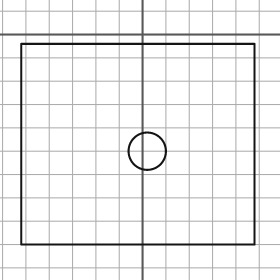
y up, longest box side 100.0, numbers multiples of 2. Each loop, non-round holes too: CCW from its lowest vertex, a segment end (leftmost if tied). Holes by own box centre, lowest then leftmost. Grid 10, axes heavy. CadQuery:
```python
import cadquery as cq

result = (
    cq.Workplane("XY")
    .moveTo(-52.0, -90.0)
    .lineTo(48.0, -90.0)
    .lineTo(48.0, -4.0)
    .lineTo(-52.0, -4.0)
    .close()
    .moveTo(2.0, -50.0)
    .circle(8.0)
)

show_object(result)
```